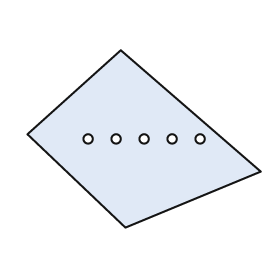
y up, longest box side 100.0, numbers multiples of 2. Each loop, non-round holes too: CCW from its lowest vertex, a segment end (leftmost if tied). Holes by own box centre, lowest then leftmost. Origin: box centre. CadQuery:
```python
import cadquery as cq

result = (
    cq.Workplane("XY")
    .moveTo(-8.0, -38.0)
    .lineTo(50.0, -14.0)
    .lineTo(-10.0, 38.0)
    .lineTo(-50.0, 2.0)
    .close()
    .moveTo(-24.0, 0.0)
    .circle(2.0)
    .moveTo(-12.0, 0.0)
    .circle(2.0)
    .moveTo(0.0, 0.0)
    .circle(2.0)
    .moveTo(12.0, 0.0)
    .circle(2.0)
    .moveTo(24.0, 0.0)
    .circle(2.0)
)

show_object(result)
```